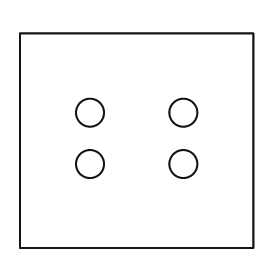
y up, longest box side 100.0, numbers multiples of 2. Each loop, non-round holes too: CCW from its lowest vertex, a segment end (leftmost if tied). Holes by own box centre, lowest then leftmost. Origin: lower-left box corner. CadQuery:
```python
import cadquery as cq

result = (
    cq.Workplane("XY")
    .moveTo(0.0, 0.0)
    .lineTo(100.0, 0.0)
    .lineTo(100.0, 92.0)
    .lineTo(0.0, 92.0)
    .close()
    .moveTo(30.0, 36.0)
    .circle(6.0)
    .moveTo(70.0, 36.0)
    .circle(6.0)
    .moveTo(30.0, 58.0)
    .circle(6.0)
    .moveTo(70.0, 58.0)
    .circle(6.0)
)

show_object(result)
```